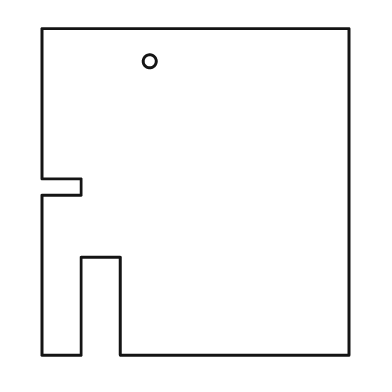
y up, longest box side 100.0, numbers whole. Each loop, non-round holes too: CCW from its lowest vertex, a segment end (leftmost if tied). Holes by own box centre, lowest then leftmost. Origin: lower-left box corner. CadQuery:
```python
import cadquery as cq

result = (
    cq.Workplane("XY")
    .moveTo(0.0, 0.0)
    .lineTo(12.0, 0.0)
    .lineTo(12.0, 30.0)
    .lineTo(24.0, 30.0)
    .lineTo(24.0, 0.0)
    .lineTo(94.0, 0.0)
    .lineTo(94.0, 100.0)
    .lineTo(0.0, 100.0)
    .lineTo(0.0, 54.0)
    .lineTo(12.0, 54.0)
    .lineTo(12.0, 49.0)
    .lineTo(0.0, 49.0)
    .close()
    .moveTo(33.0, 90.0)
    .circle(2.0)
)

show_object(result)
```